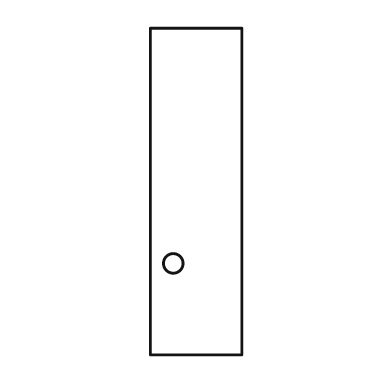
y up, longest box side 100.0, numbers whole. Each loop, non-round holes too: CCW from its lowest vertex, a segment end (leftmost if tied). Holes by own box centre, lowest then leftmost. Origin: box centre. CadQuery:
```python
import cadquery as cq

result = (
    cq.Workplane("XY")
    .moveTo(-14.0, -50.0)
    .lineTo(14.0, -50.0)
    .lineTo(14.0, 50.0)
    .lineTo(-14.0, 50.0)
    .close()
    .moveTo(-7.0, -22.0)
    .circle(3.0)
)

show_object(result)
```